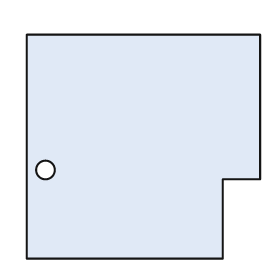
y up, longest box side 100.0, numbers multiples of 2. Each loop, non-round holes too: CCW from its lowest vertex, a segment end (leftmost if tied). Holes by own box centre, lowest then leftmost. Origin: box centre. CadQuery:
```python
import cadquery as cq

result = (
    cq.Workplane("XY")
    .moveTo(-50.0, -48.0)
    .lineTo(34.0, -48.0)
    .lineTo(34.0, -14.0)
    .lineTo(50.0, -14.0)
    .lineTo(50.0, 48.0)
    .lineTo(-50.0, 48.0)
    .close()
    .moveTo(-42.0, -10.0)
    .circle(4.0)
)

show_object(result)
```